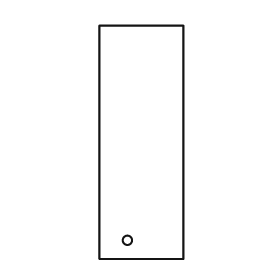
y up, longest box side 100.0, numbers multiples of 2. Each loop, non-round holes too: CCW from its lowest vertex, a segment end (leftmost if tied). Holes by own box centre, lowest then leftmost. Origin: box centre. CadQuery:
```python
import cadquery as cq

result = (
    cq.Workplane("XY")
    .moveTo(-18.0, -50.0)
    .lineTo(18.0, -50.0)
    .lineTo(18.0, 50.0)
    .lineTo(-18.0, 50.0)
    .close()
    .moveTo(-6.0, -42.0)
    .circle(2.0)
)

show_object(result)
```